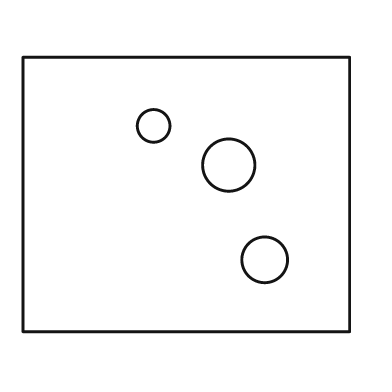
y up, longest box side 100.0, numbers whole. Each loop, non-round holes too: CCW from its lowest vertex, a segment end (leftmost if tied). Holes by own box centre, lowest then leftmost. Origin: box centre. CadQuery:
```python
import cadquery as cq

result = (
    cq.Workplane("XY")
    .moveTo(-50.0, -42.0)
    .lineTo(50.0, -42.0)
    .lineTo(50.0, 42.0)
    .lineTo(-50.0, 42.0)
    .close()
    .moveTo(24.0, -20.0)
    .circle(7.0)
    .moveTo(13.0, 9.0)
    .circle(8.0)
    .moveTo(-10.0, 21.0)
    .circle(5.0)
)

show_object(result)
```